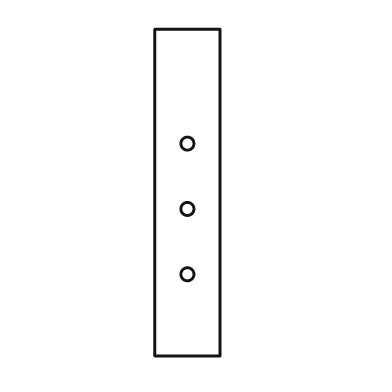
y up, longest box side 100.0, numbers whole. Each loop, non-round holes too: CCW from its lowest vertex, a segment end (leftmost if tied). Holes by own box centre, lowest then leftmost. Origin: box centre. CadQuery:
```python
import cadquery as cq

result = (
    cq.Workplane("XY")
    .moveTo(-10.0, -50.0)
    .lineTo(10.0, -50.0)
    .lineTo(10.0, 50.0)
    .lineTo(-10.0, 50.0)
    .close()
    .moveTo(0.0, -25.0)
    .circle(2.0)
    .moveTo(0.0, -5.0)
    .circle(2.0)
    .moveTo(0.0, 15.0)
    .circle(2.0)
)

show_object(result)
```